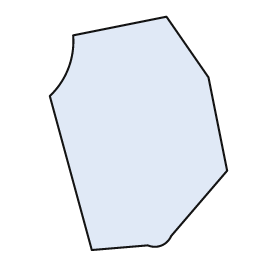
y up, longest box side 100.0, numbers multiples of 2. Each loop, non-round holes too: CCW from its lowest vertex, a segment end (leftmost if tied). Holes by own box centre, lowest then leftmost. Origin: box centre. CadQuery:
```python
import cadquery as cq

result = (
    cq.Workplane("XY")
    .moveTo(-20.0, -50.0)
    .lineTo(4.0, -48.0)
    .threePointArc((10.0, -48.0), (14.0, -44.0))
    .lineTo(38.0, -16.0)
    .lineTo(30.0, 24.0)
    .lineTo(12.0, 50.0)
    .lineTo(-28.0, 42.0)
    .threePointArc((-30.0, 28.0), (-38.0, 16.0))
    .close()
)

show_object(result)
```